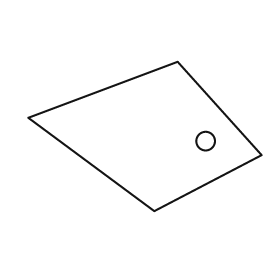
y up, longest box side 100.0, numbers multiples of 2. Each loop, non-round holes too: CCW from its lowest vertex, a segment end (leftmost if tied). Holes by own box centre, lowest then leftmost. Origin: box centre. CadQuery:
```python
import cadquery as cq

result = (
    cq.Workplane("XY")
    .moveTo(4.0, -32.0)
    .lineTo(50.0, -8.0)
    .lineTo(14.0, 32.0)
    .lineTo(-50.0, 8.0)
    .close()
    .moveTo(26.0, -2.0)
    .circle(4.0)
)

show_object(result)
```